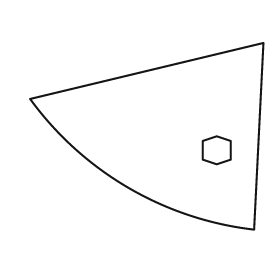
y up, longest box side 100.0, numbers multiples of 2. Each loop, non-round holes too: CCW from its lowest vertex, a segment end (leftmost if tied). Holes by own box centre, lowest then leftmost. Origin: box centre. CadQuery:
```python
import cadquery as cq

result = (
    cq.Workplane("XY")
    .moveTo(46.0, -40.0)
    .lineTo(50.0, 40.0)
    .lineTo(-50.0, 16.0)
    .threePointArc((-8.0, -22.0), (46.0, -40.0))
    .close()
    .moveTo(30.0, -12.0)
    .lineTo(36.0, -10.0)
    .lineTo(36.0, -2.0)
    .lineTo(30.0, 0.0)
    .lineTo(24.0, -2.0)
    .lineTo(24.0, -10.0)
    .close()
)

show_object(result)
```